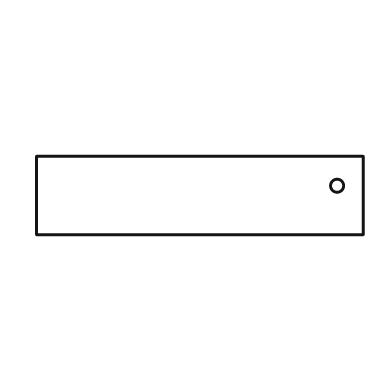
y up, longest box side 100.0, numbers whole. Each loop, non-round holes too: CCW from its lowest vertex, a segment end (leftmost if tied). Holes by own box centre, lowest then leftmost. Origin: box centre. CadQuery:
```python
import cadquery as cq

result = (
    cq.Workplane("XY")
    .moveTo(-50.0, -12.0)
    .lineTo(50.0, -12.0)
    .lineTo(50.0, 12.0)
    .lineTo(-50.0, 12.0)
    .close()
    .moveTo(42.0, 3.0)
    .circle(2.0)
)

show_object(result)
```